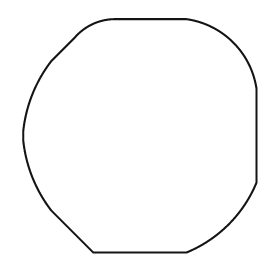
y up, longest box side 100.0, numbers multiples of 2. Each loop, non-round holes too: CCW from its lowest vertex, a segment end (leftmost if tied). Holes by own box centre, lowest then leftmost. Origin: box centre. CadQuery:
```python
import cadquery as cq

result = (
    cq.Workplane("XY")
    .moveTo(-20.0, -50.0)
    .lineTo(20.0, -50.0)
    .threePointArc((38.0, -38.0), (50.0, -20.0))
    .lineTo(50.0, 20.0)
    .threePointArc((40.0, 40.0), (20.0, 50.0))
    .lineTo(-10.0, 50.0)
    .threePointArc((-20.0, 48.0), (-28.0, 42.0))
    .lineTo(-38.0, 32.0)
    .threePointArc((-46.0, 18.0), (-50.0, 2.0))
    .lineTo(-50.0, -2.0)
    .threePointArc((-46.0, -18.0), (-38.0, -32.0))
    .close()
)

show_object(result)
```